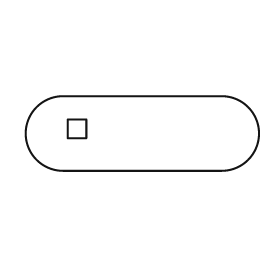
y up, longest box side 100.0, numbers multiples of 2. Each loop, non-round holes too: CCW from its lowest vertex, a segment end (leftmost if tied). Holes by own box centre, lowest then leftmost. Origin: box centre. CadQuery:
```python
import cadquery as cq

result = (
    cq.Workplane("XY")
    .moveTo(-34.0, -16.0)
    .lineTo(34.0, -16.0)
    .threePointArc((50.0, 0.0), (34.0, 16.0))
    .lineTo(-34.0, 16.0)
    .threePointArc((-50.0, 0.0), (-34.0, -16.0))
    .close()
    .moveTo(-32.0, -2.0)
    .lineTo(-24.0, -2.0)
    .lineTo(-24.0, 6.0)
    .lineTo(-32.0, 6.0)
    .close()
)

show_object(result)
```